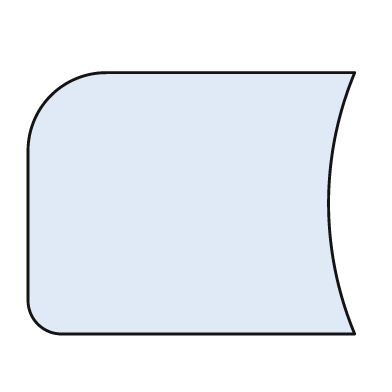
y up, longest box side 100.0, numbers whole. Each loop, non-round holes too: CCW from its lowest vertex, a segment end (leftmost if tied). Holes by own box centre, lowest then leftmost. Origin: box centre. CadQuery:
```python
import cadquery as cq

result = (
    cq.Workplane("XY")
    .moveTo(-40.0, -40.0)
    .lineTo(50.0, -40.0)
    .threePointArc((42.0, 0.0), (50.0, 40.0))
    .lineTo(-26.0, 40.0)
    .threePointArc((-43.0, 33.0), (-50.0, 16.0))
    .lineTo(-50.0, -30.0)
    .threePointArc((-47.0, -37.0), (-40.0, -40.0))
    .close()
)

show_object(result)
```